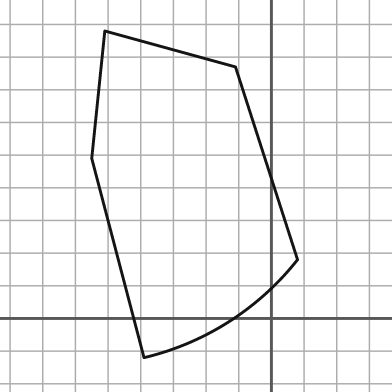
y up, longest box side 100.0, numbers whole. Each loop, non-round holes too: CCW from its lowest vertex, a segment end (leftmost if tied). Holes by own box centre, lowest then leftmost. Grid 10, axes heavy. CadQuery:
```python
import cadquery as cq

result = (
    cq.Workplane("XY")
    .moveTo(-39.0, -12.0)
    .threePointArc((-13.0, -1.0), (8.0, 18.0))
    .lineTo(-11.0, 77.0)
    .lineTo(-51.0, 88.0)
    .lineTo(-55.0, 49.0)
    .close()
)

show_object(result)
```